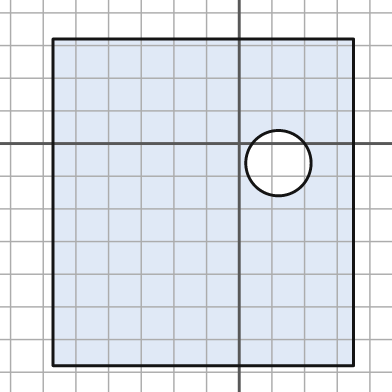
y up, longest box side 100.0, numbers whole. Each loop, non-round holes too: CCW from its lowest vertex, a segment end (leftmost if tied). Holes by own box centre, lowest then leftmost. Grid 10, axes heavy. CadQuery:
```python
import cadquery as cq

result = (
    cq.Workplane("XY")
    .moveTo(-57.0, -68.0)
    .lineTo(35.0, -68.0)
    .lineTo(35.0, 32.0)
    .lineTo(-57.0, 32.0)
    .close()
    .moveTo(12.0, -6.0)
    .circle(10.0)
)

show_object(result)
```